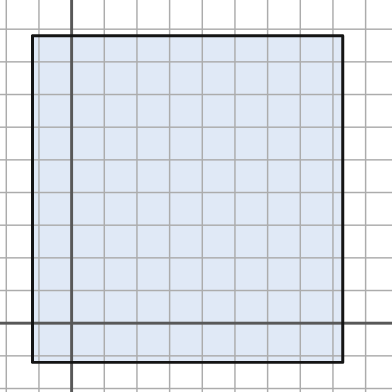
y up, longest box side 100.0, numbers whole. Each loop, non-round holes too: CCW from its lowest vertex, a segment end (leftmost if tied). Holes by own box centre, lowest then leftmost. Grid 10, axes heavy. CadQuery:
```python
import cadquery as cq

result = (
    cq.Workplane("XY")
    .moveTo(-12.0, -12.0)
    .lineTo(83.0, -12.0)
    .lineTo(83.0, 88.0)
    .lineTo(-12.0, 88.0)
    .close()
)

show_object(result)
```